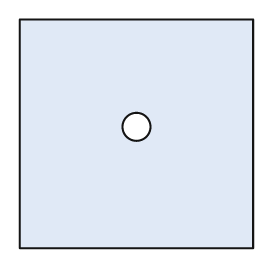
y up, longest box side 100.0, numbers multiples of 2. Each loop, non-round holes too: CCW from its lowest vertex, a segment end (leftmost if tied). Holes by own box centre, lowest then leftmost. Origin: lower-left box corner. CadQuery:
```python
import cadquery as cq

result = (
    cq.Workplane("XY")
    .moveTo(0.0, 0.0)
    .lineTo(100.0, 0.0)
    .lineTo(100.0, 98.0)
    .lineTo(0.0, 98.0)
    .close()
    .moveTo(50.0, 52.0)
    .circle(6.0)
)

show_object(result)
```